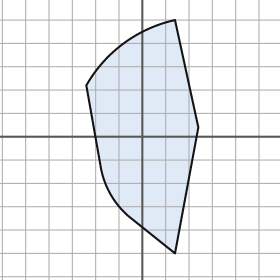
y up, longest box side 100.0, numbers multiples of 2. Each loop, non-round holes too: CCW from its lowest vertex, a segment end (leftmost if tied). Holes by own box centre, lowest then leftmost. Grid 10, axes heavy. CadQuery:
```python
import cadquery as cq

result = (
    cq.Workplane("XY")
    .moveTo(14.0, -50.0)
    .lineTo(24.0, 4.0)
    .lineTo(14.0, 50.0)
    .threePointArc((-8.0, 40.0), (-24.0, 22.0))
    .lineTo(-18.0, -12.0)
    .threePointArc((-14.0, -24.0), (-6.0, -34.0))
    .close()
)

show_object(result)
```